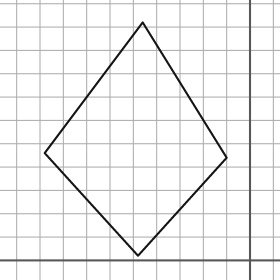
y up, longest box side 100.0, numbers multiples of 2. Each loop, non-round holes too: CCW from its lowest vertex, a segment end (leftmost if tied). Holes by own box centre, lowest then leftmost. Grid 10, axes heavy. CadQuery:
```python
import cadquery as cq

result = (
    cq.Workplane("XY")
    .moveTo(-48.0, 2.0)
    .lineTo(-10.0, 44.0)
    .lineTo(-46.0, 102.0)
    .lineTo(-88.0, 46.0)
    .close()
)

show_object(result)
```